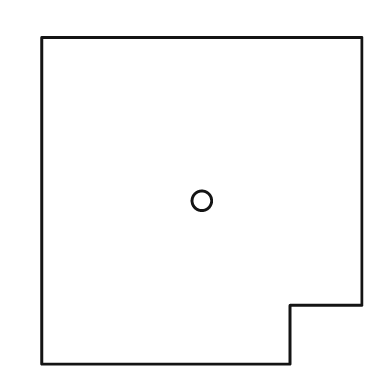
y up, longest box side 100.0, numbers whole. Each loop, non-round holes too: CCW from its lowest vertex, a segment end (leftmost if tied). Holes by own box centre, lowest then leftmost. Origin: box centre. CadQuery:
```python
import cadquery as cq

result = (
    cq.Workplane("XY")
    .moveTo(-49.0, -50.0)
    .lineTo(27.0, -50.0)
    .lineTo(27.0, -32.0)
    .lineTo(49.0, -32.0)
    .lineTo(49.0, 50.0)
    .lineTo(-49.0, 50.0)
    .close()
    .moveTo(0.0, 0.0)
    .circle(3.0)
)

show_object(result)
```